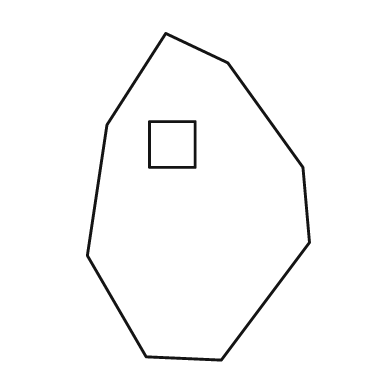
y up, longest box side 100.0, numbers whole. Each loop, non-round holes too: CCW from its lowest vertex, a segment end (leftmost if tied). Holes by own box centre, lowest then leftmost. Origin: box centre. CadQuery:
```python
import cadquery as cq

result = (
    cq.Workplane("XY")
    .moveTo(7.0, -50.0)
    .lineTo(34.0, -14.0)
    .lineTo(32.0, 9.0)
    .lineTo(9.0, 41.0)
    .lineTo(-10.0, 50.0)
    .lineTo(-28.0, 22.0)
    .lineTo(-34.0, -18.0)
    .lineTo(-16.0, -49.0)
    .close()
    .moveTo(-15.0, 9.0)
    .lineTo(-1.0, 9.0)
    .lineTo(-1.0, 23.0)
    .lineTo(-15.0, 23.0)
    .close()
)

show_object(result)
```